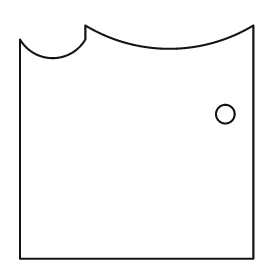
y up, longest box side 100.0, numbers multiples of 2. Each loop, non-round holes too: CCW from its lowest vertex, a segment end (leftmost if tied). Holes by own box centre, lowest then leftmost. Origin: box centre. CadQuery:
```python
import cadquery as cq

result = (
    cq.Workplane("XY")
    .moveTo(-50.0, -50.0)
    .lineTo(50.0, -50.0)
    .lineTo(50.0, 50.0)
    .threePointArc((14.0, 40.0), (-22.0, 50.0))
    .lineTo(-22.0, 44.0)
    .threePointArc((-36.0, 36.0), (-50.0, 44.0))
    .close()
    .moveTo(38.0, 12.0)
    .circle(4.0)
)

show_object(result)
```